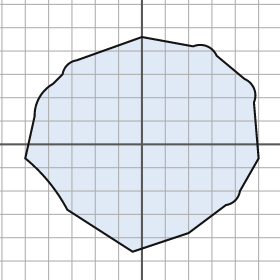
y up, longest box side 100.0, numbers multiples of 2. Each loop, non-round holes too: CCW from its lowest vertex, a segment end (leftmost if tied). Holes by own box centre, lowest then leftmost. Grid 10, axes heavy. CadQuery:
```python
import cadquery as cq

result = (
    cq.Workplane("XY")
    .moveTo(-4.0, -46.0)
    .lineTo(20.0, -38.0)
    .lineTo(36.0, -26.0)
    .threePointArc((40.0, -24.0), (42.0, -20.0))
    .lineTo(50.0, -6.0)
    .lineTo(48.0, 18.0)
    .threePointArc((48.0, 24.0), (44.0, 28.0))
    .lineTo(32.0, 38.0)
    .threePointArc((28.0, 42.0), (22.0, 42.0))
    .lineTo(0.0, 46.0)
    .lineTo(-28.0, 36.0)
    .threePointArc((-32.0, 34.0), (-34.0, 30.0))
    .lineTo(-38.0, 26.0)
    .threePointArc((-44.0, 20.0), (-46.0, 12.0))
    .lineTo(-50.0, -6.0)
    .threePointArc((-40.0, -16.0), (-32.0, -28.0))
    .close()
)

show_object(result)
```